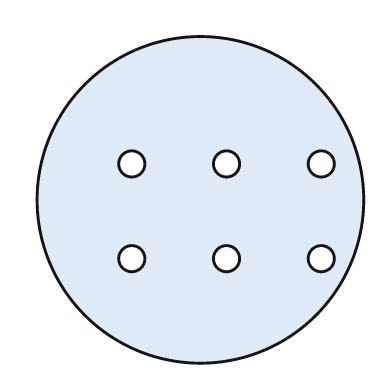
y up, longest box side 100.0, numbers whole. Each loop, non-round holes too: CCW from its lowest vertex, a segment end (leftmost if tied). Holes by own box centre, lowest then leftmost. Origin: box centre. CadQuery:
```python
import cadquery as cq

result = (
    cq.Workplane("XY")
    .moveTo(0.0, 0.0)
    .circle(50.0)
    .moveTo(-21.0, -18.0)
    .circle(4.0)
    .moveTo(8.0, -18.0)
    .circle(4.0)
    .moveTo(37.0, -18.0)
    .circle(4.0)
    .moveTo(-21.0, 11.0)
    .circle(4.0)
    .moveTo(8.0, 11.0)
    .circle(4.0)
    .moveTo(37.0, 11.0)
    .circle(4.0)
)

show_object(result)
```